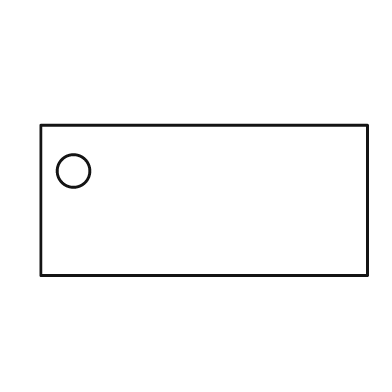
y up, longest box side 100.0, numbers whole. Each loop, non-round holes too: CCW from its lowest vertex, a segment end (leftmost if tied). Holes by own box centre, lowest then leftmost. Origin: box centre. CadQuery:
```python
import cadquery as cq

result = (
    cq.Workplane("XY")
    .moveTo(-50.0, -23.0)
    .lineTo(50.0, -23.0)
    .lineTo(50.0, 23.0)
    .lineTo(-50.0, 23.0)
    .close()
    .moveTo(-40.0, 9.0)
    .circle(5.0)
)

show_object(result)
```